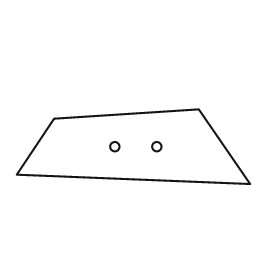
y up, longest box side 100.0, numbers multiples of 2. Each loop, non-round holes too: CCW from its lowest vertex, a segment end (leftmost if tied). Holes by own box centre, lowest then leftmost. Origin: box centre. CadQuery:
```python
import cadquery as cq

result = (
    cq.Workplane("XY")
    .moveTo(50.0, -16.0)
    .lineTo(28.0, 16.0)
    .lineTo(-34.0, 12.0)
    .lineTo(-50.0, -12.0)
    .close()
    .moveTo(-8.0, 0.0)
    .circle(2.0)
    .moveTo(10.0, 0.0)
    .circle(2.0)
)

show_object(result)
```